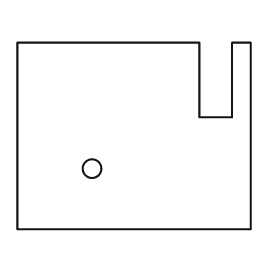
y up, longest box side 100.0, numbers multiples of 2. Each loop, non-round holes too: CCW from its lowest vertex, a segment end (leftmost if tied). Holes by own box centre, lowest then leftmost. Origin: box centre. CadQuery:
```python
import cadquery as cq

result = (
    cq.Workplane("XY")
    .moveTo(-50.0, -40.0)
    .lineTo(50.0, -40.0)
    .lineTo(50.0, 40.0)
    .lineTo(42.0, 40.0)
    .lineTo(42.0, 8.0)
    .lineTo(28.0, 8.0)
    .lineTo(28.0, 40.0)
    .lineTo(-50.0, 40.0)
    .close()
    .moveTo(-18.0, -14.0)
    .circle(4.0)
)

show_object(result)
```